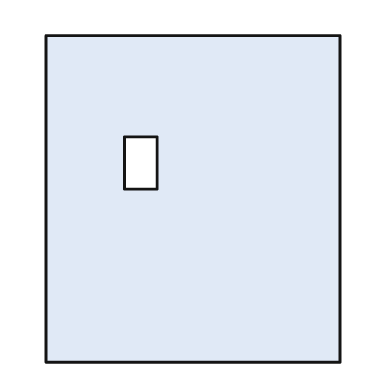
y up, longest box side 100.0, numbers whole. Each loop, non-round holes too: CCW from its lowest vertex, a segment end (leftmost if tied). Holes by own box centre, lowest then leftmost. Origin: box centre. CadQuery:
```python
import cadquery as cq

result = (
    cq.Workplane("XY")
    .moveTo(-45.0, -50.0)
    .lineTo(45.0, -50.0)
    .lineTo(45.0, 50.0)
    .lineTo(-45.0, 50.0)
    .close()
    .moveTo(-21.0, 3.0)
    .lineTo(-11.0, 3.0)
    .lineTo(-11.0, 19.0)
    .lineTo(-21.0, 19.0)
    .close()
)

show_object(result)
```